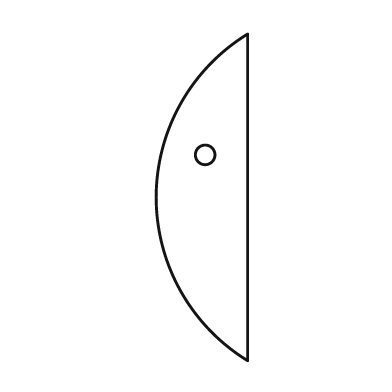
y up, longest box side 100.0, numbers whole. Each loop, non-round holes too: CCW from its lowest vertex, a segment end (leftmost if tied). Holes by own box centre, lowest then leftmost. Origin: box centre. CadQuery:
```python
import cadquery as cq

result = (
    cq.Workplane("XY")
    .moveTo(14.0, -50.0)
    .lineTo(14.0, 50.0)
    .threePointArc((-14.0, 0.0), (14.0, -50.0))
    .close()
    .moveTo(1.0, 13.0)
    .circle(3.0)
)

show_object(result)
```